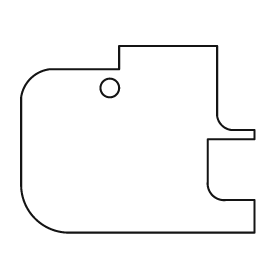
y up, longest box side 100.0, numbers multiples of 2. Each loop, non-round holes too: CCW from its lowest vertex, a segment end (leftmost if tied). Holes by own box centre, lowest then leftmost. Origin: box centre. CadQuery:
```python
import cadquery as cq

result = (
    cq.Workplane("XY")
    .moveTo(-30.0, -40.0)
    .lineTo(50.0, -40.0)
    .lineTo(50.0, -26.0)
    .lineTo(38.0, -26.0)
    .threePointArc((32.0, -24.0), (30.0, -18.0))
    .lineTo(30.0, 0.0)
    .lineTo(50.0, 0.0)
    .lineTo(50.0, 4.0)
    .lineTo(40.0, 4.0)
    .threePointArc((36.0, 6.0), (34.0, 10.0))
    .lineTo(34.0, 40.0)
    .lineTo(-8.0, 40.0)
    .lineTo(-8.0, 30.0)
    .lineTo(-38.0, 30.0)
    .threePointArc((-46.0, 26.0), (-50.0, 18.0))
    .lineTo(-50.0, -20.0)
    .threePointArc((-44.0, -34.0), (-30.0, -40.0))
    .close()
    .moveTo(-12.0, 22.0)
    .circle(4.0)
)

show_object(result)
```